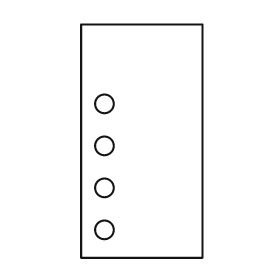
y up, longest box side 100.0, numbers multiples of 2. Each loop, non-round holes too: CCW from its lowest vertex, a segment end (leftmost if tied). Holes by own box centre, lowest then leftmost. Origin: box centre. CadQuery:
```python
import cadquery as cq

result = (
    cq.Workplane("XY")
    .moveTo(-26.0, -50.0)
    .lineTo(26.0, -50.0)
    .lineTo(26.0, 50.0)
    .lineTo(-26.0, 50.0)
    .close()
    .moveTo(-16.0, -38.0)
    .circle(4.0)
    .moveTo(-16.0, -20.0)
    .circle(4.0)
    .moveTo(-16.0, -2.0)
    .circle(4.0)
    .moveTo(-16.0, 16.0)
    .circle(4.0)
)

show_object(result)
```